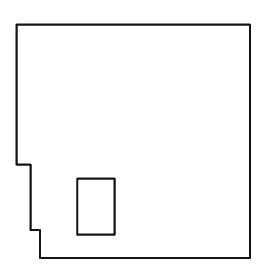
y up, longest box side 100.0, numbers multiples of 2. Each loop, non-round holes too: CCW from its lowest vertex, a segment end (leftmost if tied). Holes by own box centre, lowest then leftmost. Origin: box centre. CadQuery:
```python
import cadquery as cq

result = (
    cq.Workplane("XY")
    .moveTo(-40.0, -50.0)
    .lineTo(50.0, -50.0)
    .lineTo(50.0, 50.0)
    .lineTo(-50.0, 50.0)
    .lineTo(-50.0, -10.0)
    .lineTo(-44.0, -10.0)
    .lineTo(-44.0, -38.0)
    .lineTo(-40.0, -38.0)
    .close()
    .moveTo(-24.0, -40.0)
    .lineTo(-8.0, -40.0)
    .lineTo(-8.0, -16.0)
    .lineTo(-24.0, -16.0)
    .close()
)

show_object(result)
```